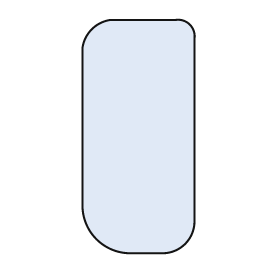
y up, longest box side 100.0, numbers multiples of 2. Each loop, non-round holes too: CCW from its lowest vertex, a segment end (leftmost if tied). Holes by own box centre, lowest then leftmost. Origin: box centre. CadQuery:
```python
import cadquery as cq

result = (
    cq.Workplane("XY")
    .moveTo(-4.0, -50.0)
    .lineTo(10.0, -50.0)
    .threePointArc((20.0, -46.0), (24.0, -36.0))
    .lineTo(24.0, 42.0)
    .threePointArc((22.0, 48.0), (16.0, 50.0))
    .lineTo(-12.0, 50.0)
    .threePointArc((-20.0, 46.0), (-24.0, 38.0))
    .lineTo(-24.0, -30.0)
    .threePointArc((-18.0, -44.0), (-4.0, -50.0))
    .close()
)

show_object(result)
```